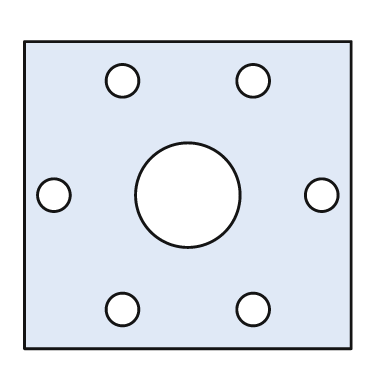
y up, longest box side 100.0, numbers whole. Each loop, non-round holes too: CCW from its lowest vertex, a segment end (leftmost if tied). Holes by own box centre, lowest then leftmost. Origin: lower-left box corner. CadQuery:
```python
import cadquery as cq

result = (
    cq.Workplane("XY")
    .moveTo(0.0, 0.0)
    .lineTo(100.0, 0.0)
    .lineTo(100.0, 94.0)
    .lineTo(0.0, 94.0)
    .close()
    .moveTo(30.0, 12.0)
    .circle(5.0)
    .moveTo(70.0, 12.0)
    .circle(5.0)
    .moveTo(9.0, 47.0)
    .circle(5.0)
    .moveTo(50.0, 47.0)
    .circle(16.0)
    .moveTo(91.0, 47.0)
    .circle(5.0)
    .moveTo(30.0, 82.0)
    .circle(5.0)
    .moveTo(70.0, 82.0)
    .circle(5.0)
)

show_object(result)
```